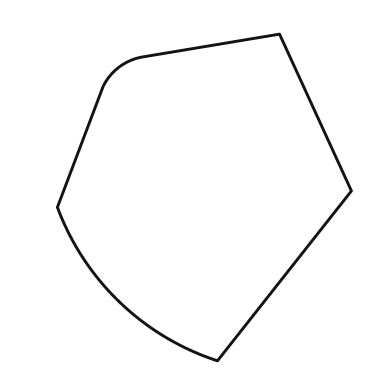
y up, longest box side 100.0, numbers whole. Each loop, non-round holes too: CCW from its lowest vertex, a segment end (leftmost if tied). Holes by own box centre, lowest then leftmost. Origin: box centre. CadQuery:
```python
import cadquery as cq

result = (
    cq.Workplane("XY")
    .moveTo(4.0, -50.0)
    .lineTo(45.0, 2.0)
    .lineTo(23.0, 50.0)
    .lineTo(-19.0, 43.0)
    .threePointArc((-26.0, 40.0), (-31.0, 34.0))
    .lineTo(-45.0, -3.0)
    .threePointArc((-26.0, -32.0), (4.0, -50.0))
    .close()
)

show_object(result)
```